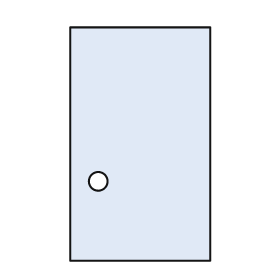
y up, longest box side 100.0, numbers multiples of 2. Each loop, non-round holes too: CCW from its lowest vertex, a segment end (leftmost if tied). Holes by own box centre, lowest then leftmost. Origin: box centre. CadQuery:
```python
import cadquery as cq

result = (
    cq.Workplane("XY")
    .moveTo(-30.0, -50.0)
    .lineTo(30.0, -50.0)
    .lineTo(30.0, 50.0)
    .lineTo(-30.0, 50.0)
    .close()
    .moveTo(-18.0, -16.0)
    .circle(4.0)
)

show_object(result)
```